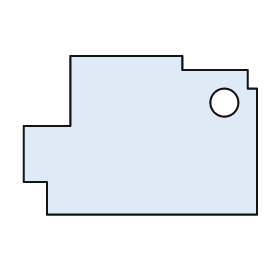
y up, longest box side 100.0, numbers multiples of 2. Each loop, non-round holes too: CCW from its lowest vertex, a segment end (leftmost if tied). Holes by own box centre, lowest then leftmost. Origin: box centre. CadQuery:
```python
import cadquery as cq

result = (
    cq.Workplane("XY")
    .moveTo(-40.0, -34.0)
    .lineTo(50.0, -34.0)
    .lineTo(50.0, 20.0)
    .lineTo(46.0, 20.0)
    .lineTo(46.0, 28.0)
    .lineTo(18.0, 28.0)
    .lineTo(18.0, 34.0)
    .lineTo(-30.0, 34.0)
    .lineTo(-30.0, 4.0)
    .lineTo(-50.0, 4.0)
    .lineTo(-50.0, -20.0)
    .lineTo(-40.0, -20.0)
    .close()
    .moveTo(36.0, 14.0)
    .circle(6.0)
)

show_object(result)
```